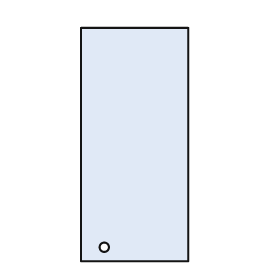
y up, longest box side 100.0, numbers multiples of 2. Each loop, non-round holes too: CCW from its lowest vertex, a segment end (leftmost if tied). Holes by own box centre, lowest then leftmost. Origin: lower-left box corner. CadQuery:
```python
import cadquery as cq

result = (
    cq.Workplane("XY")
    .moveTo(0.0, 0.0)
    .lineTo(46.0, 0.0)
    .lineTo(46.0, 100.0)
    .lineTo(0.0, 100.0)
    .close()
    .moveTo(10.0, 6.0)
    .circle(2.0)
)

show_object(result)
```